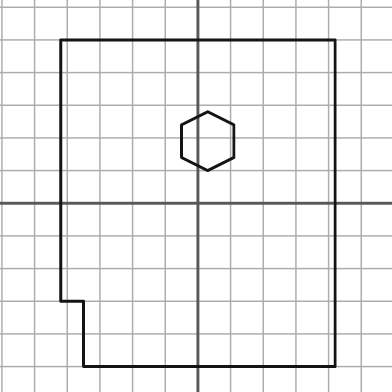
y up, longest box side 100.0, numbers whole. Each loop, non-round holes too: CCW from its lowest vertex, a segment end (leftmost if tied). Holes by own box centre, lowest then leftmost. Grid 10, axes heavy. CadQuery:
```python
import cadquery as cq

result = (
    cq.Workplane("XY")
    .moveTo(-35.0, -50.0)
    .lineTo(42.0, -50.0)
    .lineTo(42.0, 50.0)
    .lineTo(-42.0, 50.0)
    .lineTo(-42.0, -30.0)
    .lineTo(-35.0, -30.0)
    .close()
    .moveTo(3.0, 10.0)
    .lineTo(11.0, 14.0)
    .lineTo(11.0, 24.0)
    .lineTo(3.0, 28.0)
    .lineTo(-5.0, 24.0)
    .lineTo(-5.0, 14.0)
    .close()
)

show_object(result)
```